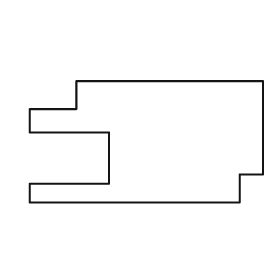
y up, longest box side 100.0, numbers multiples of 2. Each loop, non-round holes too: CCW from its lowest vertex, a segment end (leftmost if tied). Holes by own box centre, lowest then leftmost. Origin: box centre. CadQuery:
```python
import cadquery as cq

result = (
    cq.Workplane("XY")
    .moveTo(-50.0, -26.0)
    .lineTo(40.0, -26.0)
    .lineTo(40.0, -14.0)
    .lineTo(50.0, -14.0)
    .lineTo(50.0, 26.0)
    .lineTo(-30.0, 26.0)
    .lineTo(-30.0, 14.0)
    .lineTo(-50.0, 14.0)
    .lineTo(-50.0, 4.0)
    .lineTo(-16.0, 4.0)
    .lineTo(-16.0, -18.0)
    .lineTo(-50.0, -18.0)
    .close()
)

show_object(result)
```